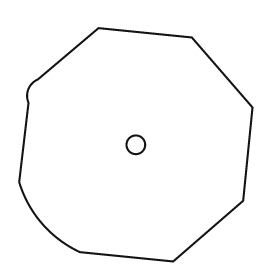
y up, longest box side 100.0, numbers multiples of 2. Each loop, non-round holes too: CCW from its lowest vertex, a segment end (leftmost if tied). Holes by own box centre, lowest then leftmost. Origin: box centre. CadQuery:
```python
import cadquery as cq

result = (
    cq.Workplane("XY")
    .moveTo(16.0, -50.0)
    .lineTo(46.0, -24.0)
    .lineTo(50.0, 16.0)
    .lineTo(24.0, 46.0)
    .lineTo(-16.0, 50.0)
    .lineTo(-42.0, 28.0)
    .threePointArc((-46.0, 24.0), (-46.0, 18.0))
    .lineTo(-50.0, -16.0)
    .threePointArc((-40.0, -34.0), (-24.0, -46.0))
    .close()
    .moveTo(0.0, 0.0)
    .circle(4.0)
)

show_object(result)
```